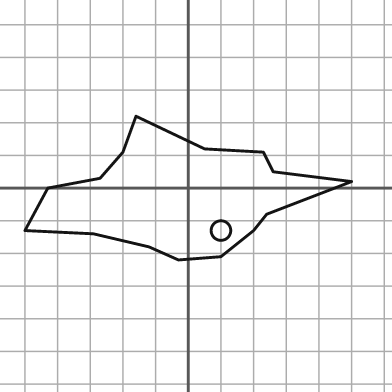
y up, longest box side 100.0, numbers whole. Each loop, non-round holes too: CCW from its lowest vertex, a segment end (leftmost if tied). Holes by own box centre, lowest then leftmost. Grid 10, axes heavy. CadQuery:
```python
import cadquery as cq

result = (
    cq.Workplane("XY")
    .moveTo(-3.0, -22.0)
    .lineTo(10.0, -21.0)
    .lineTo(20.0, -13.0)
    .lineTo(24.0, -8.0)
    .lineTo(50.0, 2.0)
    .lineTo(26.0, 5.0)
    .lineTo(23.0, 11.0)
    .lineTo(5.0, 12.0)
    .lineTo(-16.0, 22.0)
    .lineTo(-20.0, 11.0)
    .lineTo(-27.0, 3.0)
    .lineTo(-43.0, 0.0)
    .lineTo(-50.0, -13.0)
    .lineTo(-29.0, -14.0)
    .lineTo(-12.0, -18.0)
    .close()
    .moveTo(10.0, -13.0)
    .circle(3.0)
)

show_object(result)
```